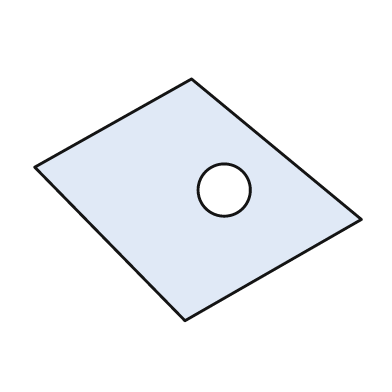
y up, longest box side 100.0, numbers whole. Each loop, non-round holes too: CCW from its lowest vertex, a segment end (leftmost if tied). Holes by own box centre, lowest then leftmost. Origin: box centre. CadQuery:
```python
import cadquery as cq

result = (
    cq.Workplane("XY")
    .moveTo(-4.0, -37.0)
    .lineTo(50.0, -6.0)
    .lineTo(-2.0, 37.0)
    .lineTo(-50.0, 10.0)
    .close()
    .moveTo(8.0, 3.0)
    .circle(8.0)
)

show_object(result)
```